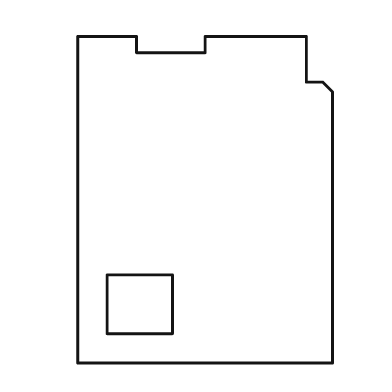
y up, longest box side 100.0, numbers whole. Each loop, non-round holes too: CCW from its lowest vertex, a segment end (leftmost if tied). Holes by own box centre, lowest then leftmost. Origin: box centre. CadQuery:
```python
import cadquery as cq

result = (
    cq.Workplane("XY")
    .moveTo(-39.0, -50.0)
    .lineTo(39.0, -50.0)
    .lineTo(39.0, 33.0)
    .lineTo(36.0, 36.0)
    .lineTo(31.0, 36.0)
    .lineTo(31.0, 50.0)
    .lineTo(0.0, 50.0)
    .lineTo(0.0, 45.0)
    .lineTo(-21.0, 45.0)
    .lineTo(-21.0, 50.0)
    .lineTo(-39.0, 50.0)
    .close()
    .moveTo(-30.0, -41.0)
    .lineTo(-10.0, -41.0)
    .lineTo(-10.0, -23.0)
    .lineTo(-30.0, -23.0)
    .close()
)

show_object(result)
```